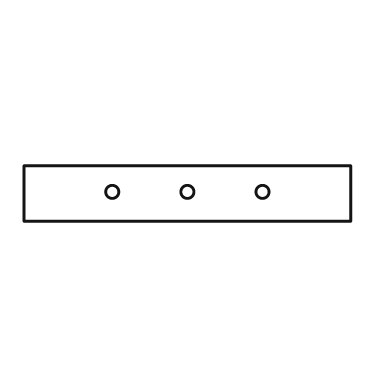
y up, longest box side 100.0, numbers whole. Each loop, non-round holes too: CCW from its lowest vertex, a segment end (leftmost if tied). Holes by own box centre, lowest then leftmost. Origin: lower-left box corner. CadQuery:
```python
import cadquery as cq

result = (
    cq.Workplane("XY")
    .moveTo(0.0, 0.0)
    .lineTo(100.0, 0.0)
    .lineTo(100.0, 17.0)
    .lineTo(0.0, 17.0)
    .close()
    .moveTo(27.0, 9.0)
    .circle(2.0)
    .moveTo(50.0, 9.0)
    .circle(2.0)
    .moveTo(73.0, 9.0)
    .circle(2.0)
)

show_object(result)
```